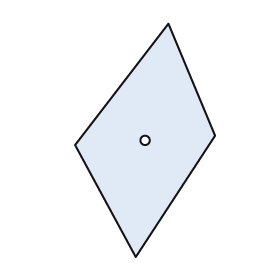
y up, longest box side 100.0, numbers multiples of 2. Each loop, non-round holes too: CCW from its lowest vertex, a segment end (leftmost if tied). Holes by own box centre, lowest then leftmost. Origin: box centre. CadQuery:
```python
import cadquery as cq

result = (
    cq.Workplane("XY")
    .moveTo(-4.0, -50.0)
    .lineTo(30.0, 2.0)
    .lineTo(10.0, 50.0)
    .lineTo(-30.0, -2.0)
    .close()
    .moveTo(0.0, 0.0)
    .circle(2.0)
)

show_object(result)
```